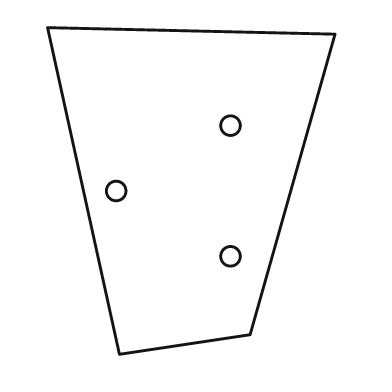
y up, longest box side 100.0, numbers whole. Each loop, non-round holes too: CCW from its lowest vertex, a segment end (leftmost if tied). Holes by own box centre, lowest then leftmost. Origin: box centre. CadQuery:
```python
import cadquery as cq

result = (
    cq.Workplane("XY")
    .moveTo(-22.0, -50.0)
    .lineTo(18.0, -44.0)
    .lineTo(44.0, 48.0)
    .lineTo(-44.0, 50.0)
    .close()
    .moveTo(12.0, -20.0)
    .circle(3.0)
    .moveTo(-23.0, 0.0)
    .circle(3.0)
    .moveTo(12.0, 20.0)
    .circle(3.0)
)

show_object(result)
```